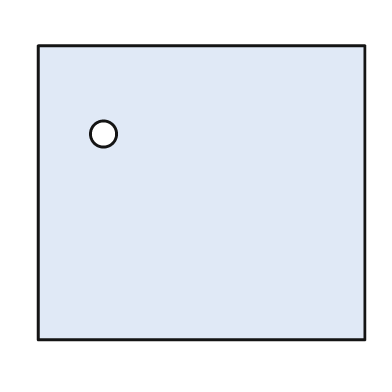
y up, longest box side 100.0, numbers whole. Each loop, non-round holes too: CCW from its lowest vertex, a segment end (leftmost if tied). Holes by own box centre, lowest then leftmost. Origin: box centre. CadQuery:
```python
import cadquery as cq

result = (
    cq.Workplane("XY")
    .moveTo(-50.0, -45.0)
    .lineTo(50.0, -45.0)
    .lineTo(50.0, 45.0)
    .lineTo(-50.0, 45.0)
    .close()
    .moveTo(-30.0, 18.0)
    .circle(4.0)
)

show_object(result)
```